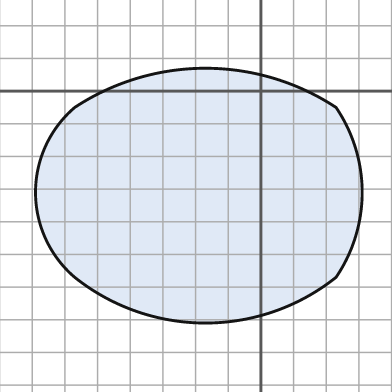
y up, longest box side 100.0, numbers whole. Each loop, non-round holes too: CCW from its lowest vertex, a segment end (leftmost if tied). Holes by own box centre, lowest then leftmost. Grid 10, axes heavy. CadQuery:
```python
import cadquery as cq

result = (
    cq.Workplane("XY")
    .moveTo(-57.0, -57.0)
    .threePointArc((-17.0, -71.0), (23.0, -57.0))
    .threePointArc((31.0, -31.0), (23.0, -5.0))
    .threePointArc((-17.0, 7.0), (-57.0, -5.0))
    .threePointArc((-69.0, -31.0), (-57.0, -57.0))
    .close()
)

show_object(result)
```